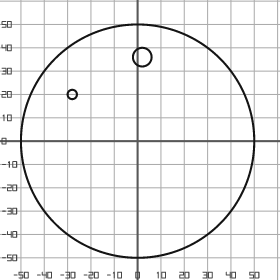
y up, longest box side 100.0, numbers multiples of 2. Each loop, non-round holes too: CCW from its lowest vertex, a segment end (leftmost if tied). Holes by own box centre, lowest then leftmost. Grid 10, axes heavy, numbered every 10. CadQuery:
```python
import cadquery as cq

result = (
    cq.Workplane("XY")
    .moveTo(0.0, 0.0)
    .circle(50.0)
    .moveTo(-28.0, 20.0)
    .circle(2.0)
    .moveTo(2.0, 36.0)
    .circle(4.0)
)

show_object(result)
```